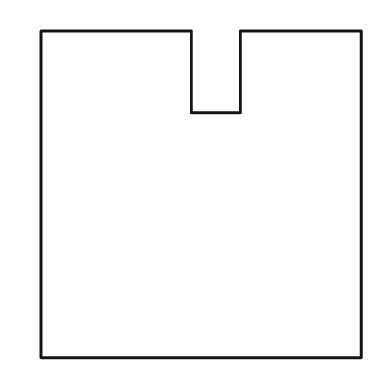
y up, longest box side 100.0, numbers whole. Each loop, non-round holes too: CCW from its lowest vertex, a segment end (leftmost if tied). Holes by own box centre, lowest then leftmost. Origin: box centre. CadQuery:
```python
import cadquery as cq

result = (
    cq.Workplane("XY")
    .moveTo(-49.0, -50.0)
    .lineTo(49.0, -50.0)
    .lineTo(49.0, 50.0)
    .lineTo(12.0, 50.0)
    .lineTo(12.0, 25.0)
    .lineTo(-3.0, 25.0)
    .lineTo(-3.0, 50.0)
    .lineTo(-49.0, 50.0)
    .close()
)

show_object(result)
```